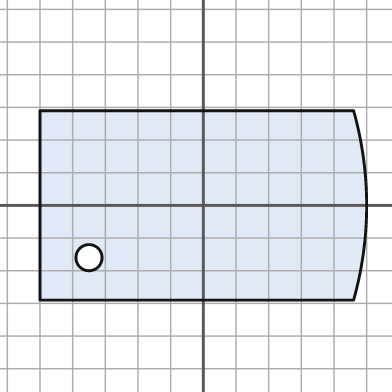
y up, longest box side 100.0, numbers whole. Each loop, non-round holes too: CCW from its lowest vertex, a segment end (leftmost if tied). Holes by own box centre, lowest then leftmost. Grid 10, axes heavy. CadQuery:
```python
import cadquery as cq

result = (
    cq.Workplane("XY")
    .moveTo(-50.0, -29.0)
    .lineTo(46.0, -29.0)
    .threePointArc((50.0, 0.0), (46.0, 29.0))
    .lineTo(-50.0, 29.0)
    .close()
    .moveTo(-35.0, -16.0)
    .circle(4.0)
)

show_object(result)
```